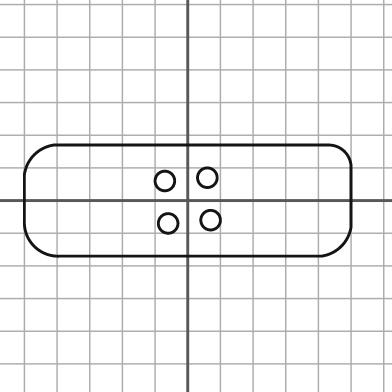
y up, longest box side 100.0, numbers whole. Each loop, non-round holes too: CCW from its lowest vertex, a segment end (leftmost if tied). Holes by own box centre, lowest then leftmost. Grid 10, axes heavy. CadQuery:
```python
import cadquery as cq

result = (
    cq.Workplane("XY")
    .moveTo(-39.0, -17.0)
    .lineTo(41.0, -17.0)
    .threePointArc((47.0, -14.0), (50.0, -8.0))
    .lineTo(50.0, 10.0)
    .threePointArc((48.0, 15.0), (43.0, 17.0))
    .lineTo(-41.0, 17.0)
    .threePointArc((-47.0, 14.0), (-50.0, 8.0))
    .lineTo(-50.0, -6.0)
    .threePointArc((-47.0, -14.0), (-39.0, -17.0))
    .close()
    .moveTo(-6.0, -7.0)
    .circle(3.0)
    .moveTo(7.0, -6.0)
    .circle(3.0)
    .moveTo(-7.0, 6.0)
    .circle(3.0)
    .moveTo(6.0, 7.0)
    .circle(3.0)
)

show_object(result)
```